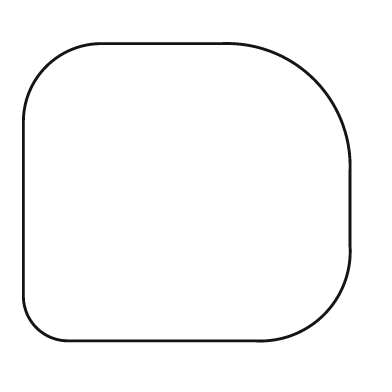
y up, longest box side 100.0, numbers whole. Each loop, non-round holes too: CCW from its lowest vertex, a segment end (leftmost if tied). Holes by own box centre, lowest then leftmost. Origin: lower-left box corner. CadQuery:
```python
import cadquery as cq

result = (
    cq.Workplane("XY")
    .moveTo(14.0, 0.0)
    .lineTo(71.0, 0.0)
    .threePointArc((92.0, 8.0), (100.0, 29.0))
    .lineTo(100.0, 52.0)
    .threePointArc((89.0, 80.0), (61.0, 91.0))
    .lineTo(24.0, 91.0)
    .threePointArc((7.0, 84.0), (0.0, 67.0))
    .lineTo(0.0, 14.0)
    .threePointArc((4.0, 4.0), (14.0, 0.0))
    .close()
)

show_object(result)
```